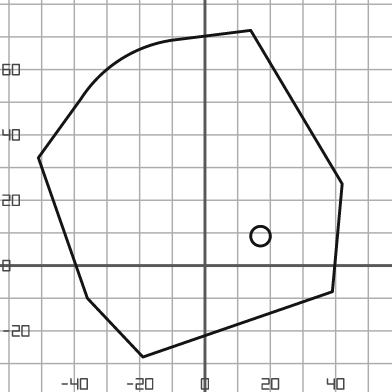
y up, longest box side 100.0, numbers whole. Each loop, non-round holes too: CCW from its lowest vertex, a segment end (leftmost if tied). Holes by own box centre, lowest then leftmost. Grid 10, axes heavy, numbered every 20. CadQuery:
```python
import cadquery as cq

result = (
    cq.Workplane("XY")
    .moveTo(-19.0, -28.0)
    .lineTo(39.0, -8.0)
    .lineTo(42.0, 25.0)
    .lineTo(14.0, 72.0)
    .lineTo(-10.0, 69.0)
    .threePointArc((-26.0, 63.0), (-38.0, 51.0))
    .lineTo(-51.0, 33.0)
    .lineTo(-36.0, -10.0)
    .close()
    .moveTo(17.0, 9.0)
    .circle(3.0)
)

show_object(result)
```